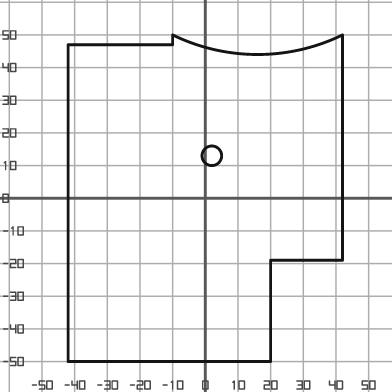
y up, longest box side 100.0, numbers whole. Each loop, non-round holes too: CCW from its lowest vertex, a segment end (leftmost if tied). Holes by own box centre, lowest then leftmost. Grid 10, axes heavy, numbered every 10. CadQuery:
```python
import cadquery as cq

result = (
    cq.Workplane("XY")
    .moveTo(-42.0, -50.0)
    .lineTo(20.0, -50.0)
    .lineTo(20.0, -19.0)
    .lineTo(42.0, -19.0)
    .lineTo(42.0, 50.0)
    .threePointArc((16.0, 44.0), (-10.0, 50.0))
    .lineTo(-10.0, 47.0)
    .lineTo(-42.0, 47.0)
    .close()
    .moveTo(2.0, 13.0)
    .circle(3.0)
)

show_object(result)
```